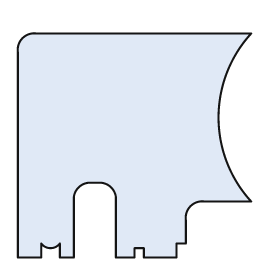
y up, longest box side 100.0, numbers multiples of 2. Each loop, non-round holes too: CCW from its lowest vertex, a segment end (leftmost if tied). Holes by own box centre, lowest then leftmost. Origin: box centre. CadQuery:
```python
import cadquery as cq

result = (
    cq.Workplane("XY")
    .moveTo(-50.0, -48.0)
    .lineTo(-40.0, -48.0)
    .lineTo(-40.0, -42.0)
    .threePointArc((-36.0, -44.0), (-32.0, -42.0))
    .lineTo(-32.0, -48.0)
    .lineTo(-26.0, -48.0)
    .lineTo(-26.0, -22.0)
    .threePointArc((-24.0, -18.0), (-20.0, -16.0))
    .lineTo(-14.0, -16.0)
    .threePointArc((-10.0, -18.0), (-8.0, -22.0))
    .lineTo(-8.0, -48.0)
    .lineTo(0.0, -48.0)
    .lineTo(0.0, -44.0)
    .lineTo(4.0, -44.0)
    .lineTo(4.0, -48.0)
    .lineTo(18.0, -48.0)
    .lineTo(18.0, -42.0)
    .lineTo(22.0, -42.0)
    .lineTo(22.0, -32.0)
    .threePointArc((24.0, -26.0), (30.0, -24.0))
    .lineTo(50.0, -24.0)
    .threePointArc((36.0, 12.0), (50.0, 48.0))
    .lineTo(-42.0, 48.0)
    .threePointArc((-48.0, 46.0), (-50.0, 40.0))
    .close()
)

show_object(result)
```